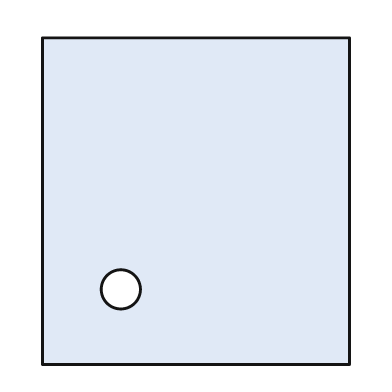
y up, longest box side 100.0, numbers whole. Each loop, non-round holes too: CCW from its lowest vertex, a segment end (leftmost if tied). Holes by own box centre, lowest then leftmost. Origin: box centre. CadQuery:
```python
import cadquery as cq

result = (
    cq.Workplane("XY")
    .moveTo(-47.0, -50.0)
    .lineTo(47.0, -50.0)
    .lineTo(47.0, 50.0)
    .lineTo(-47.0, 50.0)
    .close()
    .moveTo(-23.0, -27.0)
    .circle(6.0)
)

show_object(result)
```